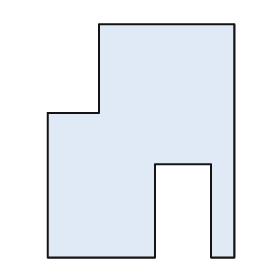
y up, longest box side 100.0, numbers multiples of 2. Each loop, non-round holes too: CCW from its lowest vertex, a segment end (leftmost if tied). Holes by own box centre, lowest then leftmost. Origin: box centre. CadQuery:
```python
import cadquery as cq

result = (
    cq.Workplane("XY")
    .moveTo(-40.0, -50.0)
    .lineTo(6.0, -50.0)
    .lineTo(6.0, -10.0)
    .lineTo(30.0, -10.0)
    .lineTo(30.0, -50.0)
    .lineTo(40.0, -50.0)
    .lineTo(40.0, 50.0)
    .lineTo(-18.0, 50.0)
    .lineTo(-18.0, 12.0)
    .lineTo(-40.0, 12.0)
    .close()
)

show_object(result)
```